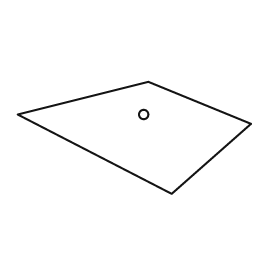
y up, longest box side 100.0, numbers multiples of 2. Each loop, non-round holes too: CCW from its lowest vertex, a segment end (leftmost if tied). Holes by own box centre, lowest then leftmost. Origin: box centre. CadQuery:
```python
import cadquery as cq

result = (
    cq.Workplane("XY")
    .moveTo(16.0, -24.0)
    .lineTo(50.0, 6.0)
    .lineTo(6.0, 24.0)
    .lineTo(-50.0, 10.0)
    .close()
    .moveTo(4.0, 10.0)
    .circle(2.0)
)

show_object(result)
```